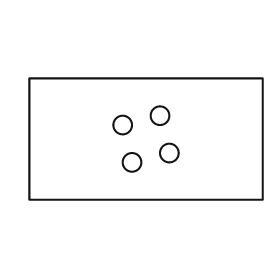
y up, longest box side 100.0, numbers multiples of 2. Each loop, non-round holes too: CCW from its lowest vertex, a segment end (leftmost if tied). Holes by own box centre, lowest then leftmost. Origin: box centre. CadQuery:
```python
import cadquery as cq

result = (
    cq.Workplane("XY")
    .moveTo(-50.0, -26.0)
    .lineTo(50.0, -26.0)
    .lineTo(50.0, 26.0)
    .lineTo(-50.0, 26.0)
    .close()
    .moveTo(-6.0, -10.0)
    .circle(4.0)
    .moveTo(10.0, -6.0)
    .circle(4.0)
    .moveTo(-10.0, 6.0)
    .circle(4.0)
    .moveTo(6.0, 10.0)
    .circle(4.0)
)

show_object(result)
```